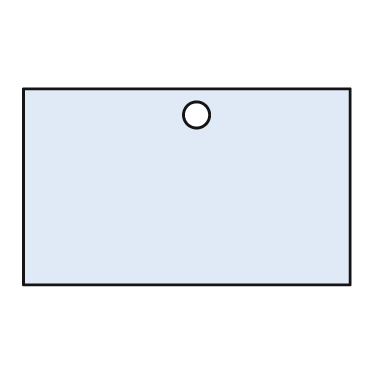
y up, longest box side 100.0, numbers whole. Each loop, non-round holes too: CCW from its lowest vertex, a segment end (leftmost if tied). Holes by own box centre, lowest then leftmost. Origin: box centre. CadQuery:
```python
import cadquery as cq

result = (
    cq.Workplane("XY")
    .moveTo(-50.0, -30.0)
    .lineTo(50.0, -30.0)
    .lineTo(50.0, 30.0)
    .lineTo(-50.0, 30.0)
    .close()
    .moveTo(3.0, 22.0)
    .circle(4.0)
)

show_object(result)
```